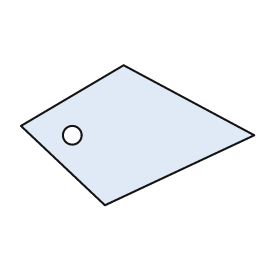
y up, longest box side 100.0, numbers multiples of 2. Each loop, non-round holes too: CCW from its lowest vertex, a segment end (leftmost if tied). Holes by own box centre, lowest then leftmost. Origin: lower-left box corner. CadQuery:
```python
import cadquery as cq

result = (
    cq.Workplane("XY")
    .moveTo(36.0, 0.0)
    .lineTo(100.0, 30.0)
    .lineTo(44.0, 60.0)
    .lineTo(0.0, 34.0)
    .close()
    .moveTo(22.0, 30.0)
    .circle(4.0)
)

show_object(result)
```